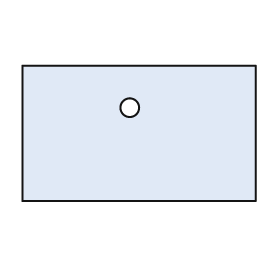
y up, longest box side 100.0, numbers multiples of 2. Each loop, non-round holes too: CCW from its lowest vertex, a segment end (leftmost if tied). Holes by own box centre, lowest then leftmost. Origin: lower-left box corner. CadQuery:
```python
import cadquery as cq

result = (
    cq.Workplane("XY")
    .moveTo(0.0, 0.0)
    .lineTo(100.0, 0.0)
    .lineTo(100.0, 58.0)
    .lineTo(0.0, 58.0)
    .close()
    .moveTo(46.0, 40.0)
    .circle(4.0)
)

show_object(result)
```